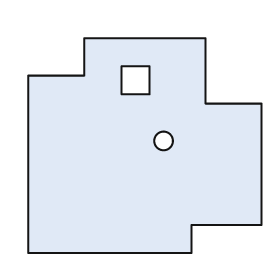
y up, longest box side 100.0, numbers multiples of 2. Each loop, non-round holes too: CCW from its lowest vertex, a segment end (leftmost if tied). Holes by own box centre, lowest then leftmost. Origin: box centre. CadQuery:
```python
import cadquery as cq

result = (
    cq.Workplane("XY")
    .moveTo(-50.0, -46.0)
    .lineTo(20.0, -46.0)
    .lineTo(20.0, -34.0)
    .lineTo(50.0, -34.0)
    .lineTo(50.0, 18.0)
    .lineTo(26.0, 18.0)
    .lineTo(26.0, 46.0)
    .lineTo(-26.0, 46.0)
    .lineTo(-26.0, 30.0)
    .lineTo(-50.0, 30.0)
    .close()
    .moveTo(8.0, 2.0)
    .circle(4.0)
    .moveTo(-10.0, 22.0)
    .lineTo(2.0, 22.0)
    .lineTo(2.0, 34.0)
    .lineTo(-10.0, 34.0)
    .close()
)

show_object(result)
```